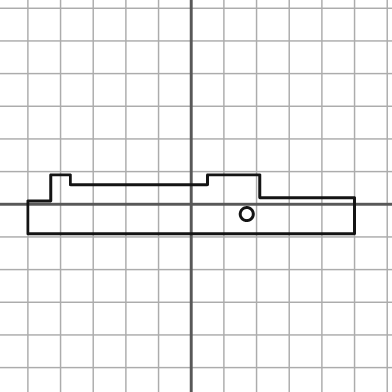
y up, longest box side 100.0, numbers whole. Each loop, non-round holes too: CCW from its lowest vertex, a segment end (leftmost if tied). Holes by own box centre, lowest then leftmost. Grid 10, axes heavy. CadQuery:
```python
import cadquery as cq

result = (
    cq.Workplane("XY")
    .moveTo(-50.0, -9.0)
    .lineTo(50.0, -9.0)
    .lineTo(50.0, 2.0)
    .lineTo(21.0, 2.0)
    .lineTo(21.0, 9.0)
    .lineTo(5.0, 9.0)
    .lineTo(5.0, 6.0)
    .lineTo(-37.0, 6.0)
    .lineTo(-37.0, 9.0)
    .lineTo(-43.0, 9.0)
    .lineTo(-43.0, 1.0)
    .lineTo(-50.0, 1.0)
    .close()
    .moveTo(17.0, -3.0)
    .circle(2.0)
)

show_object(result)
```